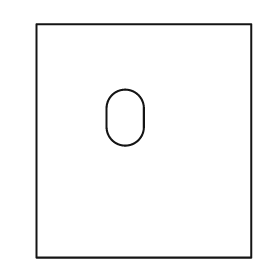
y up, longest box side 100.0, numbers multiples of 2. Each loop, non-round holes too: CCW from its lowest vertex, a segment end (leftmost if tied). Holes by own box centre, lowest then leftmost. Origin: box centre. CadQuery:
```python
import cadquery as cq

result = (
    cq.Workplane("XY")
    .moveTo(-46.0, -50.0)
    .lineTo(46.0, -50.0)
    .lineTo(46.0, 50.0)
    .lineTo(-46.0, 50.0)
    .close()
    .moveTo(-16.0, 6.0)
    .threePointArc((-8.0, -2.0), (0.0, 6.0))
    .lineTo(0.0, 14.0)
    .threePointArc((-8.0, 22.0), (-16.0, 14.0))
    .close()
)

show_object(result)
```